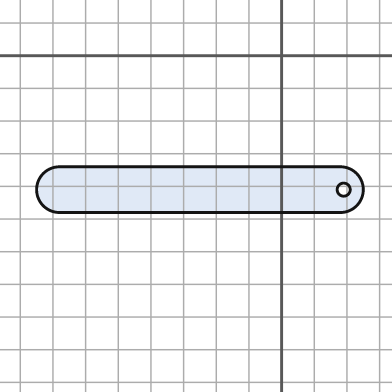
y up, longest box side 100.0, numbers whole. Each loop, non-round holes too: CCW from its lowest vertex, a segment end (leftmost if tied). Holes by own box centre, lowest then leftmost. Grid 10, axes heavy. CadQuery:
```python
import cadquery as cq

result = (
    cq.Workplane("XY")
    .moveTo(-68.0, -48.0)
    .lineTo(18.0, -48.0)
    .threePointArc((25.0, -41.0), (18.0, -34.0))
    .lineTo(-68.0, -34.0)
    .threePointArc((-75.0, -41.0), (-68.0, -48.0))
    .close()
    .moveTo(19.0, -41.0)
    .circle(2.0)
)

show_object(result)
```